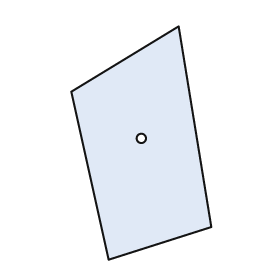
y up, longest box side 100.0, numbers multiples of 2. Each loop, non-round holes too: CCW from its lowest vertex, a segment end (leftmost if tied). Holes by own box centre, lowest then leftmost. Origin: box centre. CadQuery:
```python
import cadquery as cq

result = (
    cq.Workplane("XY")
    .moveTo(-14.0, -50.0)
    .lineTo(30.0, -36.0)
    .lineTo(16.0, 50.0)
    .lineTo(-30.0, 22.0)
    .close()
    .moveTo(0.0, 2.0)
    .circle(2.0)
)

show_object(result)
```